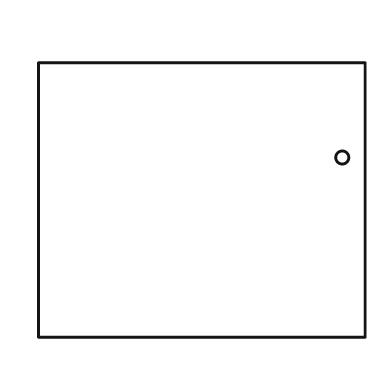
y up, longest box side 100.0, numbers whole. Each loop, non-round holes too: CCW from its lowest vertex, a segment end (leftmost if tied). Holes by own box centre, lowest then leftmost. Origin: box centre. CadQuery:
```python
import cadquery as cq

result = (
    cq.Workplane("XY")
    .moveTo(-50.0, -42.0)
    .lineTo(50.0, -42.0)
    .lineTo(50.0, 42.0)
    .lineTo(-50.0, 42.0)
    .close()
    .moveTo(43.0, 13.0)
    .circle(2.0)
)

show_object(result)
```